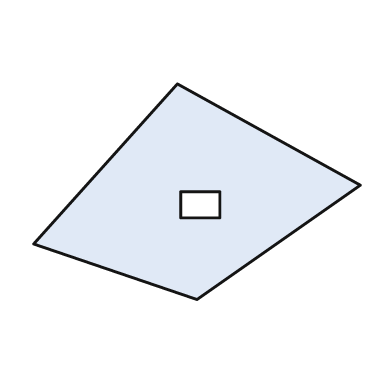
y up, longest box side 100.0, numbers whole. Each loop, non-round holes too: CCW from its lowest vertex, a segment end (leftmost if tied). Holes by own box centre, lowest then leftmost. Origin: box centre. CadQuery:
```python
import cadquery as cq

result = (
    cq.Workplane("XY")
    .moveTo(0.0, -33.0)
    .lineTo(50.0, 2.0)
    .lineTo(-6.0, 33.0)
    .lineTo(-50.0, -16.0)
    .close()
    .moveTo(-5.0, -8.0)
    .lineTo(7.0, -8.0)
    .lineTo(7.0, 0.0)
    .lineTo(-5.0, 0.0)
    .close()
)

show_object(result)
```